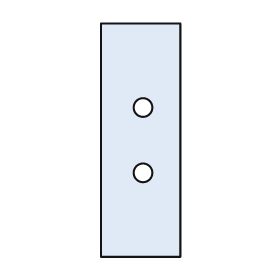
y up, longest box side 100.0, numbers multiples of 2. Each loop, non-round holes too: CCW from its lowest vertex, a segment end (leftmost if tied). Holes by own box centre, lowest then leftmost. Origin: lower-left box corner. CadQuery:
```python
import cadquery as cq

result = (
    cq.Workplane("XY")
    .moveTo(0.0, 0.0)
    .lineTo(34.0, 0.0)
    .lineTo(34.0, 100.0)
    .lineTo(0.0, 100.0)
    .close()
    .moveTo(18.0, 36.0)
    .circle(4.0)
    .moveTo(18.0, 64.0)
    .circle(4.0)
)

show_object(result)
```